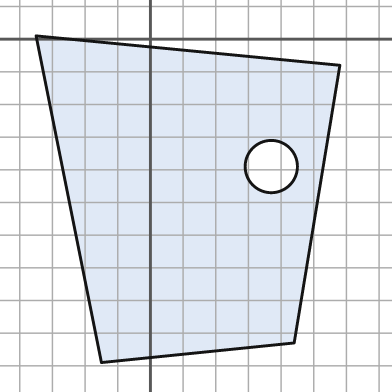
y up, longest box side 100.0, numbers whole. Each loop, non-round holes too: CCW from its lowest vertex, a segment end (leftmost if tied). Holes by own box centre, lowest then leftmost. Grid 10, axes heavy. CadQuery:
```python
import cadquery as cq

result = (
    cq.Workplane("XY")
    .moveTo(-15.0, -99.0)
    .lineTo(44.0, -93.0)
    .lineTo(58.0, -8.0)
    .lineTo(-35.0, 1.0)
    .close()
    .moveTo(37.0, -39.0)
    .circle(8.0)
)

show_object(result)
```